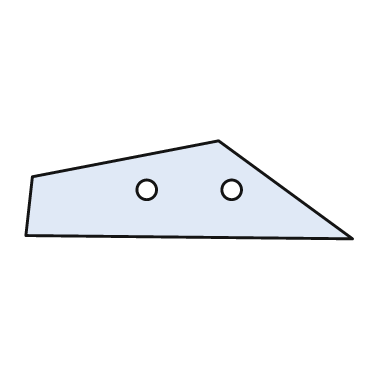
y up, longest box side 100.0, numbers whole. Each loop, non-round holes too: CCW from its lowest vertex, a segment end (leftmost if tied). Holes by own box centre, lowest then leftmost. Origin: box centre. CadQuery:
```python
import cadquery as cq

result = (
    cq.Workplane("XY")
    .moveTo(50.0, -15.0)
    .lineTo(9.0, 15.0)
    .lineTo(-48.0, 4.0)
    .lineTo(-50.0, -14.0)
    .close()
    .moveTo(-13.0, 0.0)
    .circle(3.0)
    .moveTo(13.0, 0.0)
    .circle(3.0)
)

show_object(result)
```